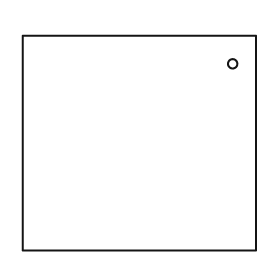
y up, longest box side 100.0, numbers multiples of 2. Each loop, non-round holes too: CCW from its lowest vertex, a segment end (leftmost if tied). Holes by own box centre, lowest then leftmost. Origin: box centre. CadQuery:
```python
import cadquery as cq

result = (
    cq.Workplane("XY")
    .moveTo(-50.0, -46.0)
    .lineTo(50.0, -46.0)
    .lineTo(50.0, 46.0)
    .lineTo(-50.0, 46.0)
    .close()
    .moveTo(40.0, 34.0)
    .circle(2.0)
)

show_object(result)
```